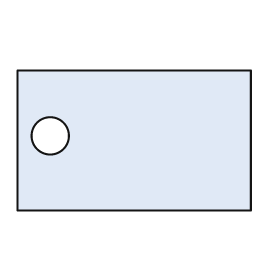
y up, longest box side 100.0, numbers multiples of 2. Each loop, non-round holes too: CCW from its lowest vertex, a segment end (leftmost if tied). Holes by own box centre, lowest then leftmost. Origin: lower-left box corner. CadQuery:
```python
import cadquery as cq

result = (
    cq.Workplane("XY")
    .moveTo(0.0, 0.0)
    .lineTo(100.0, 0.0)
    .lineTo(100.0, 60.0)
    .lineTo(0.0, 60.0)
    .close()
    .moveTo(14.0, 32.0)
    .circle(8.0)
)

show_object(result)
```